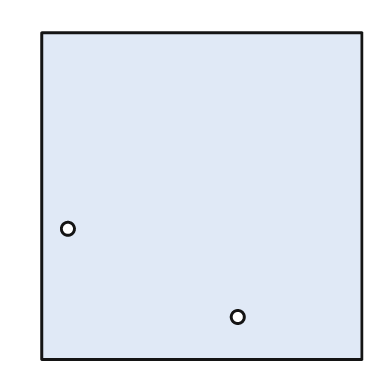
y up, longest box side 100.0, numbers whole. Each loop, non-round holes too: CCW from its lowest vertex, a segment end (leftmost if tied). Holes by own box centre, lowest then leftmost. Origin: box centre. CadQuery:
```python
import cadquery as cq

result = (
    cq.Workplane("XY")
    .moveTo(-49.0, -50.0)
    .lineTo(49.0, -50.0)
    .lineTo(49.0, 50.0)
    .lineTo(-49.0, 50.0)
    .close()
    .moveTo(11.0, -37.0)
    .circle(2.0)
    .moveTo(-41.0, -10.0)
    .circle(2.0)
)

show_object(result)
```